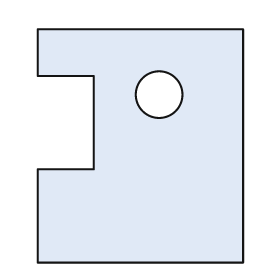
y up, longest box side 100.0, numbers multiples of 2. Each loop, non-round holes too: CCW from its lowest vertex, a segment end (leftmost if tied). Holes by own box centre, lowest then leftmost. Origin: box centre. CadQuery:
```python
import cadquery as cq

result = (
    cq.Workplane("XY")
    .moveTo(-44.0, -50.0)
    .lineTo(44.0, -50.0)
    .lineTo(44.0, 50.0)
    .lineTo(-44.0, 50.0)
    .lineTo(-44.0, 30.0)
    .lineTo(-20.0, 30.0)
    .lineTo(-20.0, -10.0)
    .lineTo(-44.0, -10.0)
    .close()
    .moveTo(8.0, 22.0)
    .circle(10.0)
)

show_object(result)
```